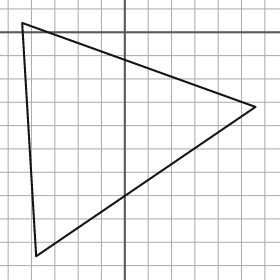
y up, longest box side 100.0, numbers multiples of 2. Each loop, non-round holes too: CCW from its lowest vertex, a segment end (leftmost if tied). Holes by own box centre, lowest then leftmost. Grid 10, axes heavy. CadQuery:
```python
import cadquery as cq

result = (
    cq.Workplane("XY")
    .moveTo(-38.0, -96.0)
    .lineTo(56.0, -32.0)
    .lineTo(-44.0, 4.0)
    .close()
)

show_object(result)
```